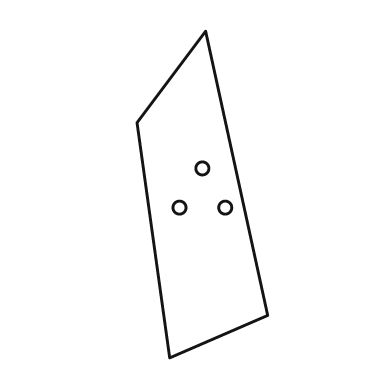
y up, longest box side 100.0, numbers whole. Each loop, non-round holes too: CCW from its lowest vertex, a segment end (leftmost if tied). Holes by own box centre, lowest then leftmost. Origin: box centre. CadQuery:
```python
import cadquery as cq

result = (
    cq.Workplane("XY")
    .moveTo(-10.0, -50.0)
    .lineTo(20.0, -37.0)
    .lineTo(1.0, 50.0)
    .lineTo(-20.0, 22.0)
    .close()
    .moveTo(-7.0, -4.0)
    .circle(2.0)
    .moveTo(7.0, -4.0)
    .circle(2.0)
    .moveTo(0.0, 8.0)
    .circle(2.0)
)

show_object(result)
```